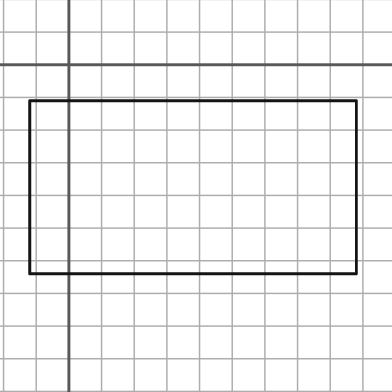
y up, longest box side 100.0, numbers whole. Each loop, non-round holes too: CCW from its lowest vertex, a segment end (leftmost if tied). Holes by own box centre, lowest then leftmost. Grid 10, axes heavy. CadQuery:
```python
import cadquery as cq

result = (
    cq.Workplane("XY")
    .moveTo(-12.0, -64.0)
    .lineTo(88.0, -64.0)
    .lineTo(88.0, -11.0)
    .lineTo(-12.0, -11.0)
    .close()
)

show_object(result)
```